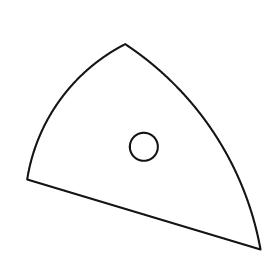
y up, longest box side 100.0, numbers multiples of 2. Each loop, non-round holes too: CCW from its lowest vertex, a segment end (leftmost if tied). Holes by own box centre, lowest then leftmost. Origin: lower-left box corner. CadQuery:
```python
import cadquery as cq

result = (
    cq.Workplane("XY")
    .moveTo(100.0, 0.0)
    .threePointArc((80.0, 50.0), (42.0, 88.0))
    .threePointArc((14.0, 64.0), (0.0, 30.0))
    .close()
    .moveTo(50.0, 44.0)
    .circle(6.0)
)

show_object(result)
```